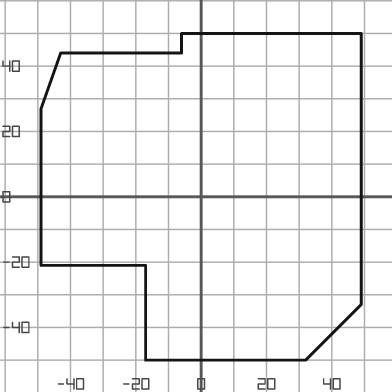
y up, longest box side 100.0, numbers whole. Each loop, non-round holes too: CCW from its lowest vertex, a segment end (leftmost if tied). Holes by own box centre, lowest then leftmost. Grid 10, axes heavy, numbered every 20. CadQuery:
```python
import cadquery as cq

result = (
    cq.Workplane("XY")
    .moveTo(-17.0, -50.0)
    .lineTo(32.0, -50.0)
    .lineTo(49.0, -33.0)
    .lineTo(49.0, 50.0)
    .lineTo(-6.0, 50.0)
    .lineTo(-6.0, 44.0)
    .lineTo(-43.0, 44.0)
    .lineTo(-49.0, 27.0)
    .lineTo(-49.0, -21.0)
    .lineTo(-17.0, -21.0)
    .close()
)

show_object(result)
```